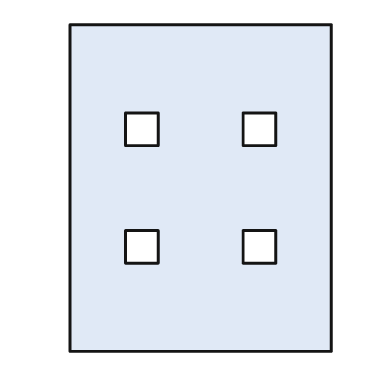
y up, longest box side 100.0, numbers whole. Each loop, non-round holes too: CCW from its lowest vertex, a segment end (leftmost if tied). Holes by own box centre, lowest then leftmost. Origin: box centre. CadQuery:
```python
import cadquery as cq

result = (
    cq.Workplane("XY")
    .moveTo(-40.0, -50.0)
    .lineTo(40.0, -50.0)
    .lineTo(40.0, 50.0)
    .lineTo(-40.0, 50.0)
    .close()
    .moveTo(-23.0, -23.0)
    .lineTo(-13.0, -23.0)
    .lineTo(-13.0, -13.0)
    .lineTo(-23.0, -13.0)
    .close()
    .moveTo(13.0, -23.0)
    .lineTo(23.0, -23.0)
    .lineTo(23.0, -13.0)
    .lineTo(13.0, -13.0)
    .close()
    .moveTo(-23.0, 13.0)
    .lineTo(-13.0, 13.0)
    .lineTo(-13.0, 23.0)
    .lineTo(-23.0, 23.0)
    .close()
    .moveTo(13.0, 13.0)
    .lineTo(23.0, 13.0)
    .lineTo(23.0, 23.0)
    .lineTo(13.0, 23.0)
    .close()
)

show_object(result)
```